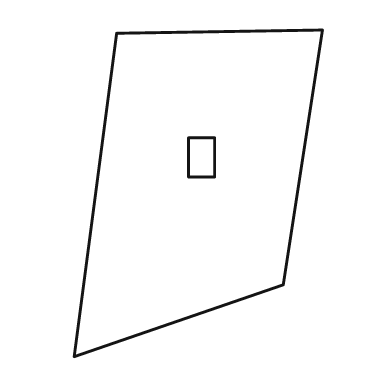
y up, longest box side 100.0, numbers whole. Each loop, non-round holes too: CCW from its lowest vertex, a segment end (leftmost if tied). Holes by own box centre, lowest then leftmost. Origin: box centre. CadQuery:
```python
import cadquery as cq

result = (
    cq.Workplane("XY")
    .moveTo(-38.0, -50.0)
    .lineTo(26.0, -28.0)
    .lineTo(38.0, 50.0)
    .lineTo(-25.0, 49.0)
    .close()
    .moveTo(-3.0, 5.0)
    .lineTo(5.0, 5.0)
    .lineTo(5.0, 17.0)
    .lineTo(-3.0, 17.0)
    .close()
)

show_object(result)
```